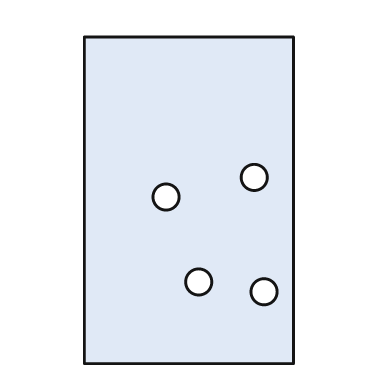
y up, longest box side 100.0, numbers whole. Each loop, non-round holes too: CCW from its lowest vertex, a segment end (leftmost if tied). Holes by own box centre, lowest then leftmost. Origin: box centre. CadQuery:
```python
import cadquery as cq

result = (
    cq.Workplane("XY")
    .moveTo(-32.0, -50.0)
    .lineTo(32.0, -50.0)
    .lineTo(32.0, 50.0)
    .lineTo(-32.0, 50.0)
    .close()
    .moveTo(23.0, -28.0)
    .circle(4.0)
    .moveTo(3.0, -25.0)
    .circle(4.0)
    .moveTo(-7.0, 1.0)
    .circle(4.0)
    .moveTo(20.0, 7.0)
    .circle(4.0)
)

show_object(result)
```